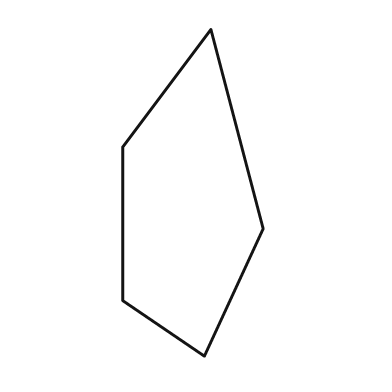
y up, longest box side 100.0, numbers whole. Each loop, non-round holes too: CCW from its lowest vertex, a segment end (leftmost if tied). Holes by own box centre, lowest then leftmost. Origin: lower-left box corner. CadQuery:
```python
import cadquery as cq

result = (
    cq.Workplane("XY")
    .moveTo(25.0, 0.0)
    .lineTo(43.0, 39.0)
    .lineTo(27.0, 100.0)
    .lineTo(0.0, 64.0)
    .lineTo(0.0, 17.0)
    .close()
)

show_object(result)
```